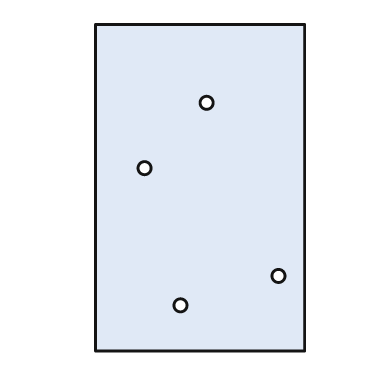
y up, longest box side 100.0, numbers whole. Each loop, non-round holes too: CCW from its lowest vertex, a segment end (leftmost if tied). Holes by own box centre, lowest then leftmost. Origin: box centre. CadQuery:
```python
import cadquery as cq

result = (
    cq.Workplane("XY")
    .moveTo(-32.0, -50.0)
    .lineTo(32.0, -50.0)
    .lineTo(32.0, 50.0)
    .lineTo(-32.0, 50.0)
    .close()
    .moveTo(-6.0, -36.0)
    .circle(2.0)
    .moveTo(24.0, -27.0)
    .circle(2.0)
    .moveTo(-17.0, 6.0)
    .circle(2.0)
    .moveTo(2.0, 26.0)
    .circle(2.0)
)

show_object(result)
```